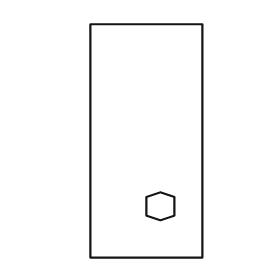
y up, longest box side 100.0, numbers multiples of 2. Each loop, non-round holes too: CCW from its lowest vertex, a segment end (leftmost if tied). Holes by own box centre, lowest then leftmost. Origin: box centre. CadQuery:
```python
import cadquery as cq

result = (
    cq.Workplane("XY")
    .moveTo(-24.0, -50.0)
    .lineTo(24.0, -50.0)
    .lineTo(24.0, 50.0)
    .lineTo(-24.0, 50.0)
    .close()
    .moveTo(6.0, -34.0)
    .lineTo(12.0, -32.0)
    .lineTo(12.0, -24.0)
    .lineTo(6.0, -22.0)
    .lineTo(0.0, -24.0)
    .lineTo(0.0, -32.0)
    .close()
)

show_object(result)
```